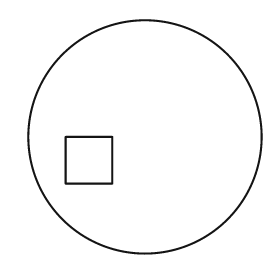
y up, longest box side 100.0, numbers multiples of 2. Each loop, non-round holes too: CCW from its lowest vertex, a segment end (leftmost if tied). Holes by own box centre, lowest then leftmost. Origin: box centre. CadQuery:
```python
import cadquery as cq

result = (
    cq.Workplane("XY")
    .moveTo(0.0, 0.0)
    .circle(50.0)
    .moveTo(-34.0, -20.0)
    .lineTo(-14.0, -20.0)
    .lineTo(-14.0, 0.0)
    .lineTo(-34.0, 0.0)
    .close()
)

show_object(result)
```